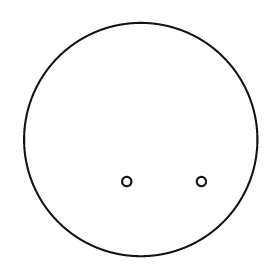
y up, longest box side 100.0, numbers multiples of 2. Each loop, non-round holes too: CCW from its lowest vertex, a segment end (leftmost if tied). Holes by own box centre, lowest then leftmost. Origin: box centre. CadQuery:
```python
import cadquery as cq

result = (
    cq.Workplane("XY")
    .moveTo(0.0, 0.0)
    .circle(50.0)
    .moveTo(-6.0, -18.0)
    .circle(2.0)
    .moveTo(26.0, -18.0)
    .circle(2.0)
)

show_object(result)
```